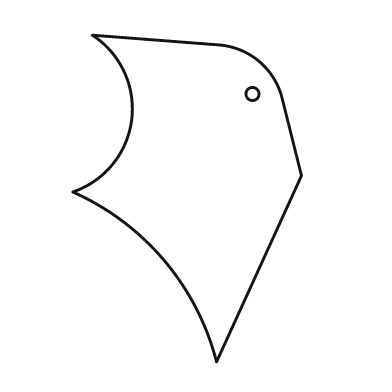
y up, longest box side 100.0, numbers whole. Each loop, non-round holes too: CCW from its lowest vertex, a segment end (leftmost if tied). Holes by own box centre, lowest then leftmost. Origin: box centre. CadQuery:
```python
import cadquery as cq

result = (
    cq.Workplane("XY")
    .moveTo(9.0, -50.0)
    .lineTo(35.0, 7.0)
    .lineTo(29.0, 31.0)
    .threePointArc((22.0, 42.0), (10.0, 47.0))
    .lineTo(-29.0, 50.0)
    .threePointArc((-17.0, 24.0), (-35.0, 2.0))
    .threePointArc((-7.0, -19.0), (9.0, -50.0))
    .close()
    .moveTo(20.0, 32.0)
    .circle(2.0)
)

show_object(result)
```